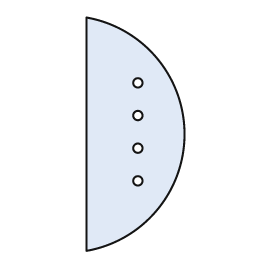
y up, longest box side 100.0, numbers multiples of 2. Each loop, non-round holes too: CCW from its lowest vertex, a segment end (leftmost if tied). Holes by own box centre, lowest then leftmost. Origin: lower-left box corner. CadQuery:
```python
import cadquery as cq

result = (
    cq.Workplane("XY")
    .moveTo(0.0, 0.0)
    .threePointArc((42.0, 50.0), (0.0, 100.0))
    .close()
    .moveTo(22.0, 30.0)
    .circle(2.0)
    .moveTo(22.0, 44.0)
    .circle(2.0)
    .moveTo(22.0, 58.0)
    .circle(2.0)
    .moveTo(22.0, 72.0)
    .circle(2.0)
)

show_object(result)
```